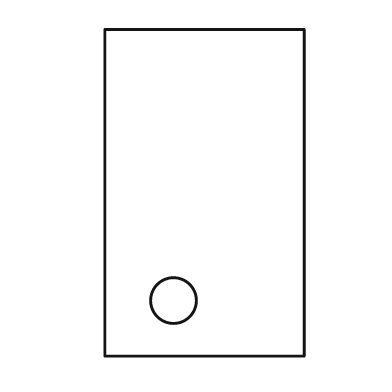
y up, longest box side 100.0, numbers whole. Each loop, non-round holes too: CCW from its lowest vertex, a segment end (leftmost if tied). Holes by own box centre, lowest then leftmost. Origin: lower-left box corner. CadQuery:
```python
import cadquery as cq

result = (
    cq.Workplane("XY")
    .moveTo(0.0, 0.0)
    .lineTo(61.0, 0.0)
    .lineTo(61.0, 100.0)
    .lineTo(0.0, 100.0)
    .close()
    .moveTo(21.0, 17.0)
    .circle(7.0)
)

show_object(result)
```